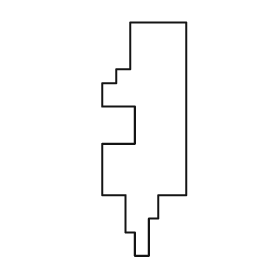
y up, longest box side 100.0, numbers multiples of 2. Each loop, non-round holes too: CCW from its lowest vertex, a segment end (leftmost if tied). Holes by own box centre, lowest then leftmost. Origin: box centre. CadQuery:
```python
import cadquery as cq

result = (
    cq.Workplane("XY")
    .moveTo(-4.0, -50.0)
    .lineTo(2.0, -50.0)
    .lineTo(2.0, -34.0)
    .lineTo(6.0, -34.0)
    .lineTo(6.0, -24.0)
    .lineTo(18.0, -24.0)
    .lineTo(18.0, 50.0)
    .lineTo(-6.0, 50.0)
    .lineTo(-6.0, 30.0)
    .lineTo(-12.0, 30.0)
    .lineTo(-12.0, 24.0)
    .lineTo(-18.0, 24.0)
    .lineTo(-18.0, 14.0)
    .lineTo(-4.0, 14.0)
    .lineTo(-4.0, -2.0)
    .lineTo(-18.0, -2.0)
    .lineTo(-18.0, -24.0)
    .lineTo(-8.0, -24.0)
    .lineTo(-8.0, -40.0)
    .lineTo(-4.0, -40.0)
    .close()
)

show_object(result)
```